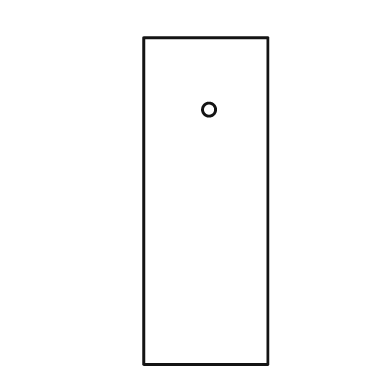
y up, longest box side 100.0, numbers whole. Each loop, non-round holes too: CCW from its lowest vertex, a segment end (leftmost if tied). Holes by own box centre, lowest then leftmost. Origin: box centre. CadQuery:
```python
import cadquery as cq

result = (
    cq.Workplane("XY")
    .moveTo(-19.0, -50.0)
    .lineTo(19.0, -50.0)
    .lineTo(19.0, 50.0)
    .lineTo(-19.0, 50.0)
    .close()
    .moveTo(1.0, 28.0)
    .circle(2.0)
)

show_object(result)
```